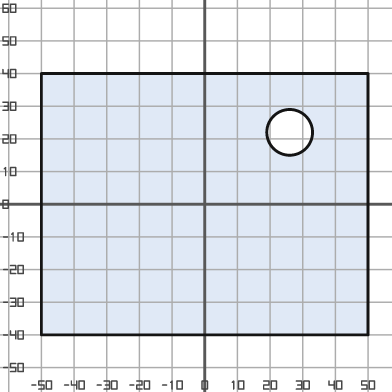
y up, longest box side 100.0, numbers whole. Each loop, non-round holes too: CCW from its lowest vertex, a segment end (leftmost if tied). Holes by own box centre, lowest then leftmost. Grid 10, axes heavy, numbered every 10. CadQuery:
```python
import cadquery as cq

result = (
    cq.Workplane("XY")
    .moveTo(-50.0, -40.0)
    .lineTo(50.0, -40.0)
    .lineTo(50.0, 40.0)
    .lineTo(-50.0, 40.0)
    .close()
    .moveTo(26.0, 22.0)
    .circle(7.0)
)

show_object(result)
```